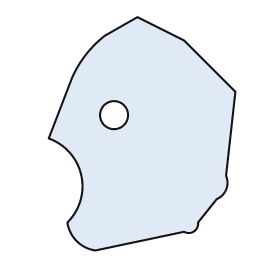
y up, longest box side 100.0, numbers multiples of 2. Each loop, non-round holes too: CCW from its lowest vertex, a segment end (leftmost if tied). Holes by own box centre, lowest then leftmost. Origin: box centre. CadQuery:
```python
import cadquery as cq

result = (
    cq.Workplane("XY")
    .moveTo(-20.0, -50.0)
    .lineTo(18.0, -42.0)
    .threePointArc((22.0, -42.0), (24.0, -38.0))
    .lineTo(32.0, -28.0)
    .threePointArc((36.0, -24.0), (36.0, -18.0))
    .lineTo(40.0, 18.0)
    .lineTo(18.0, 40.0)
    .lineTo(-2.0, 50.0)
    .lineTo(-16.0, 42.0)
    .threePointArc((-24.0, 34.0), (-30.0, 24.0))
    .lineTo(-40.0, -2.0)
    .threePointArc((-26.0, -18.0), (-32.0, -38.0))
    .threePointArc((-28.0, -46.0), (-20.0, -50.0))
    .close()
    .moveTo(-12.0, 8.0)
    .circle(6.0)
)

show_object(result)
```